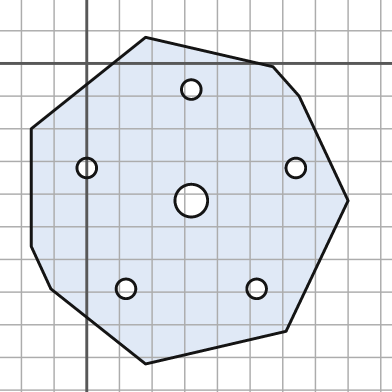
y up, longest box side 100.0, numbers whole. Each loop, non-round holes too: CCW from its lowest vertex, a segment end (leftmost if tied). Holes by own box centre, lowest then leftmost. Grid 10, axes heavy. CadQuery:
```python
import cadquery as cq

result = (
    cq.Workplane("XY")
    .moveTo(18.0, -92.0)
    .lineTo(61.0, -82.0)
    .lineTo(80.0, -42.0)
    .lineTo(65.0, -10.0)
    .lineTo(57.0, -1.0)
    .lineTo(18.0, 8.0)
    .lineTo(-17.0, -20.0)
    .lineTo(-17.0, -56.0)
    .lineTo(-11.0, -69.0)
    .close()
    .moveTo(12.0, -69.0)
    .circle(3.0)
    .moveTo(52.0, -69.0)
    .circle(3.0)
    .moveTo(32.0, -42.0)
    .circle(5.0)
    .moveTo(0.0, -32.0)
    .circle(3.0)
    .moveTo(64.0, -32.0)
    .circle(3.0)
    .moveTo(32.0, -8.0)
    .circle(3.0)
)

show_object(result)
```